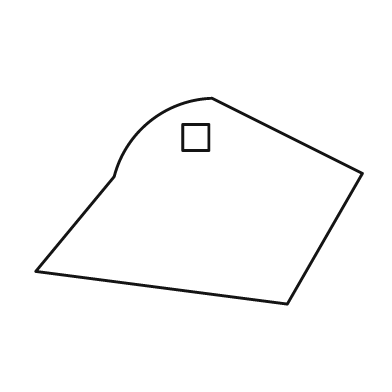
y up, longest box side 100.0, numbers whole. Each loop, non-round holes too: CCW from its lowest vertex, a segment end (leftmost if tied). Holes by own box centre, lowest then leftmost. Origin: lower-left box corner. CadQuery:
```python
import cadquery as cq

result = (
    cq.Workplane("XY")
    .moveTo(77.0, 0.0)
    .lineTo(100.0, 40.0)
    .lineTo(54.0, 63.0)
    .threePointArc((35.0, 56.0), (24.0, 39.0))
    .lineTo(0.0, 10.0)
    .close()
    .moveTo(45.0, 47.0)
    .lineTo(53.0, 47.0)
    .lineTo(53.0, 55.0)
    .lineTo(45.0, 55.0)
    .close()
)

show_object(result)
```